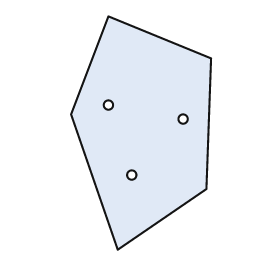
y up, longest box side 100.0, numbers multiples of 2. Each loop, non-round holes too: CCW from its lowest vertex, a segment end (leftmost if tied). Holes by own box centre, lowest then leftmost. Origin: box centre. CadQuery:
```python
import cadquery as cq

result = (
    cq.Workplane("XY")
    .moveTo(-10.0, -50.0)
    .lineTo(28.0, -24.0)
    .lineTo(30.0, 32.0)
    .lineTo(-14.0, 50.0)
    .lineTo(-30.0, 8.0)
    .close()
    .moveTo(-4.0, -18.0)
    .circle(2.0)
    .moveTo(18.0, 6.0)
    .circle(2.0)
    .moveTo(-14.0, 12.0)
    .circle(2.0)
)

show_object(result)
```